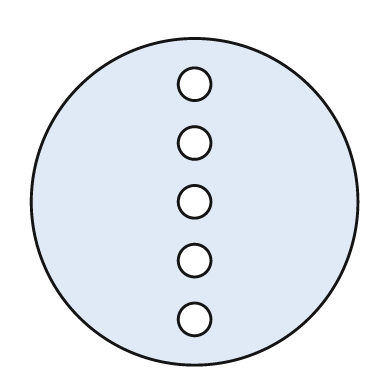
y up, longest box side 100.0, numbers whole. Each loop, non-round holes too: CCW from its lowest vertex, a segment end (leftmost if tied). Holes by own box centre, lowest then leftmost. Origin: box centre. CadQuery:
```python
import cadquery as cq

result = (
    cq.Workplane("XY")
    .moveTo(0.0, 0.0)
    .circle(50.0)
    .moveTo(0.0, -36.0)
    .circle(5.0)
    .moveTo(0.0, -18.0)
    .circle(5.0)
    .moveTo(0.0, 0.0)
    .circle(5.0)
    .moveTo(0.0, 18.0)
    .circle(5.0)
    .moveTo(0.0, 36.0)
    .circle(5.0)
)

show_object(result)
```